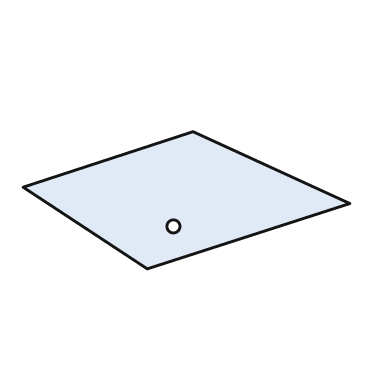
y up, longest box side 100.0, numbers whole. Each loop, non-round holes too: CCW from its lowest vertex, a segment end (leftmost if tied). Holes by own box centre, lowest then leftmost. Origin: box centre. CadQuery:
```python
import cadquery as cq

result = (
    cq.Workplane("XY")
    .moveTo(-12.0, -21.0)
    .lineTo(50.0, -1.0)
    .lineTo(2.0, 21.0)
    .lineTo(-50.0, 4.0)
    .close()
    .moveTo(-4.0, -8.0)
    .circle(2.0)
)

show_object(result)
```